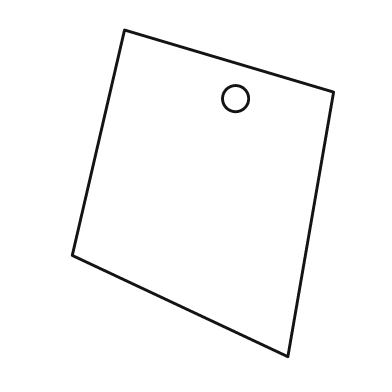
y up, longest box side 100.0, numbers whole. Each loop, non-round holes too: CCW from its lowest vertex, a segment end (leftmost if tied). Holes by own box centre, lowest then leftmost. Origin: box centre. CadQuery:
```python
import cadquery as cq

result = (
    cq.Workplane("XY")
    .moveTo(26.0, -50.0)
    .lineTo(40.0, 31.0)
    .lineTo(-24.0, 50.0)
    .lineTo(-40.0, -19.0)
    .close()
    .moveTo(10.0, 29.0)
    .circle(4.0)
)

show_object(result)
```